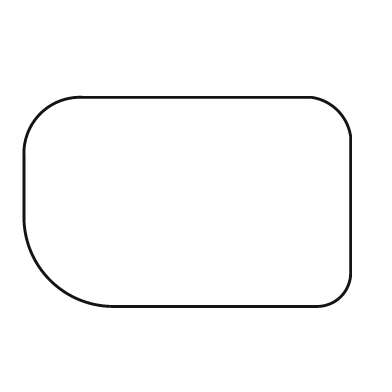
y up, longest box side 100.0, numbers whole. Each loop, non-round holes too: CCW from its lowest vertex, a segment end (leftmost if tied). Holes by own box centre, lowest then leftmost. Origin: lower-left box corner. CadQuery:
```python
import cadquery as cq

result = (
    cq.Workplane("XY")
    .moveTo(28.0, 0.0)
    .lineTo(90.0, 0.0)
    .threePointArc((97.0, 3.0), (100.0, 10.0))
    .lineTo(100.0, 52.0)
    .threePointArc((96.0, 60.0), (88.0, 64.0))
    .lineTo(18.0, 64.0)
    .threePointArc((5.0, 59.0), (0.0, 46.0))
    .lineTo(0.0, 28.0)
    .threePointArc((8.0, 8.0), (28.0, 0.0))
    .close()
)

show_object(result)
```